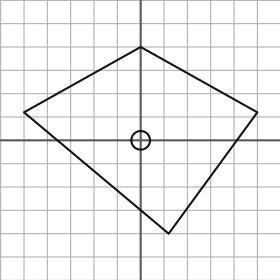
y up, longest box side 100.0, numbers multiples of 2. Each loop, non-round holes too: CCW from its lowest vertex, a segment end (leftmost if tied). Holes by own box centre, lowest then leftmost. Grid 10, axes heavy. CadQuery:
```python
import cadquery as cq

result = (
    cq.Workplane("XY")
    .moveTo(12.0, -40.0)
    .lineTo(50.0, 12.0)
    .lineTo(0.0, 40.0)
    .lineTo(-50.0, 12.0)
    .close()
    .moveTo(0.0, 0.0)
    .circle(4.0)
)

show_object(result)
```